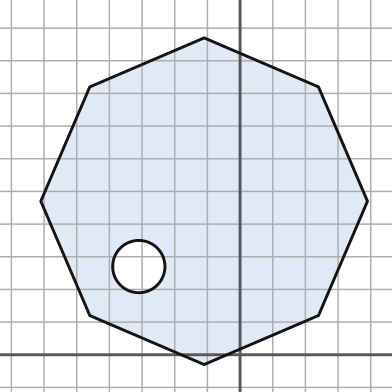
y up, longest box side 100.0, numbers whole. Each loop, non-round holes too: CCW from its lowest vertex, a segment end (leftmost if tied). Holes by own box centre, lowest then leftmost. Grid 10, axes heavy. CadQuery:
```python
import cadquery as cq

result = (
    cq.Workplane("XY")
    .moveTo(-11.0, -3.0)
    .lineTo(24.0, 12.0)
    .lineTo(39.0, 47.0)
    .lineTo(24.0, 82.0)
    .lineTo(-11.0, 97.0)
    .lineTo(-46.0, 82.0)
    .lineTo(-61.0, 47.0)
    .lineTo(-46.0, 12.0)
    .close()
    .moveTo(-31.0, 27.0)
    .circle(8.0)
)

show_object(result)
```